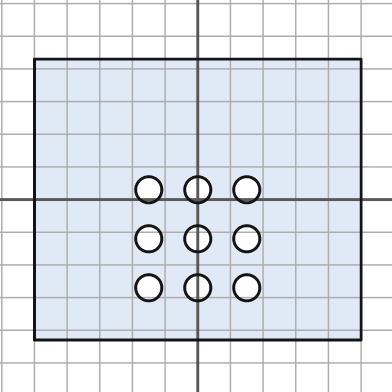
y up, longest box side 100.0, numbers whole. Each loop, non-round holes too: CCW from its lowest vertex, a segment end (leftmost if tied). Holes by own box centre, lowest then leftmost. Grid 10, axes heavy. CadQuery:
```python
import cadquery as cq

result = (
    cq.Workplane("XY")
    .moveTo(-50.0, -43.0)
    .lineTo(50.0, -43.0)
    .lineTo(50.0, 43.0)
    .lineTo(-50.0, 43.0)
    .close()
    .moveTo(-15.0, -27.0)
    .circle(4.0)
    .moveTo(0.0, -27.0)
    .circle(4.0)
    .moveTo(15.0, -27.0)
    .circle(4.0)
    .moveTo(-15.0, -12.0)
    .circle(4.0)
    .moveTo(0.0, -12.0)
    .circle(4.0)
    .moveTo(15.0, -12.0)
    .circle(4.0)
    .moveTo(-15.0, 3.0)
    .circle(4.0)
    .moveTo(0.0, 3.0)
    .circle(4.0)
    .moveTo(15.0, 3.0)
    .circle(4.0)
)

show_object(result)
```